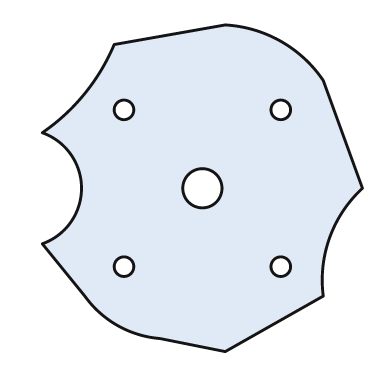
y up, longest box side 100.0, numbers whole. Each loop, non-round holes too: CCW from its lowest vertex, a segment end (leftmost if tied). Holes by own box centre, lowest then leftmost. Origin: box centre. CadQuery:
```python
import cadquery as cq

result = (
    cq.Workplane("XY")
    .moveTo(7.0, -50.0)
    .lineTo(37.0, -33.0)
    .threePointArc((39.0, -15.0), (49.0, 0.0))
    .lineTo(37.0, 33.0)
    .threePointArc((24.0, 45.0), (7.0, 50.0))
    .lineTo(-27.0, 44.0)
    .threePointArc((-36.0, 29.0), (-49.0, 17.0))
    .threePointArc((-37.0, 0.0), (-49.0, -17.0))
    .lineTo(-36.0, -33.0)
    .threePointArc((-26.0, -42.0), (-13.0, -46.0))
    .close()
    .moveTo(-24.0, -24.0)
    .circle(3.0)
    .moveTo(24.0, -24.0)
    .circle(3.0)
    .moveTo(0.0, 0.0)
    .circle(6.0)
    .moveTo(-24.0, 24.0)
    .circle(3.0)
    .moveTo(24.0, 24.0)
    .circle(3.0)
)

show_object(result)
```